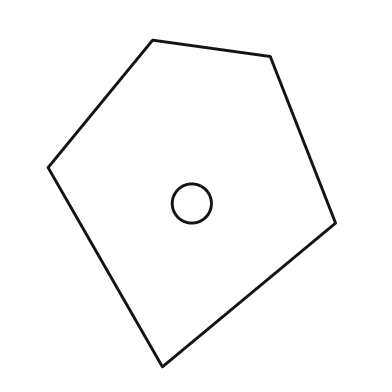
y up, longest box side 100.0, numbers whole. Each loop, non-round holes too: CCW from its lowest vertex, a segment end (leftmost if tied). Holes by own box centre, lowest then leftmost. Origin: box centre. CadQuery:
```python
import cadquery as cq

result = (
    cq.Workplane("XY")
    .moveTo(-9.0, -50.0)
    .lineTo(44.0, -6.0)
    .lineTo(24.0, 45.0)
    .lineTo(-12.0, 50.0)
    .lineTo(-44.0, 11.0)
    .close()
    .moveTo(0.0, 0.0)
    .circle(6.0)
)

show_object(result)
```